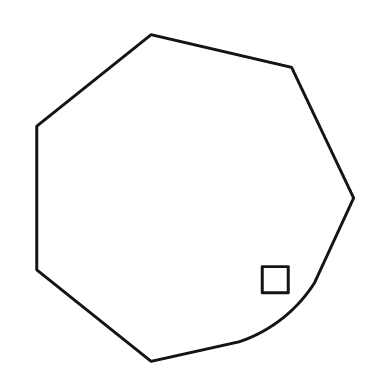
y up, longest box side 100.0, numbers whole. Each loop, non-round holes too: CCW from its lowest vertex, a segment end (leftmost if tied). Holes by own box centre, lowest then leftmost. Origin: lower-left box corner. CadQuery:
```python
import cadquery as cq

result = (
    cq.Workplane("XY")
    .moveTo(35.0, 0.0)
    .lineTo(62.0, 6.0)
    .threePointArc((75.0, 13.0), (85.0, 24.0))
    .lineTo(97.0, 50.0)
    .lineTo(78.0, 90.0)
    .lineTo(35.0, 100.0)
    .lineTo(0.0, 72.0)
    .lineTo(0.0, 28.0)
    .close()
    .moveTo(69.0, 21.0)
    .lineTo(77.0, 21.0)
    .lineTo(77.0, 29.0)
    .lineTo(69.0, 29.0)
    .close()
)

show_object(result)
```